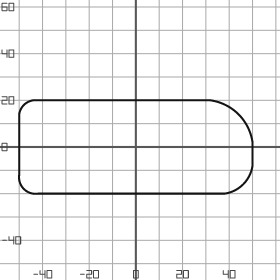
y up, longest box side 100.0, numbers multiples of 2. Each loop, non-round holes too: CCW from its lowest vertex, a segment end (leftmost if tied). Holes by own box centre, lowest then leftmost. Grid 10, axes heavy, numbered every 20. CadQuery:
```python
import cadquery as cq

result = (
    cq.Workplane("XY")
    .moveTo(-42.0, -20.0)
    .lineTo(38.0, -20.0)
    .threePointArc((46.0, -16.0), (50.0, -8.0))
    .lineTo(50.0, 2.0)
    .threePointArc((44.0, 14.0), (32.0, 20.0))
    .lineTo(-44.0, 20.0)
    .threePointArc((-48.0, 18.0), (-50.0, 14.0))
    .lineTo(-50.0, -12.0)
    .threePointArc((-48.0, -18.0), (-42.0, -20.0))
    .close()
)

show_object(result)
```